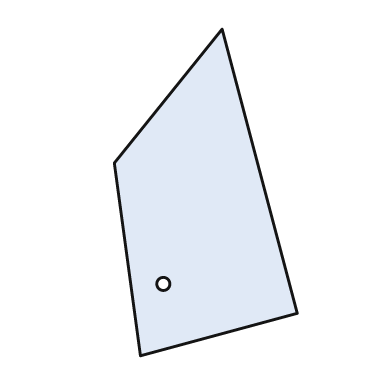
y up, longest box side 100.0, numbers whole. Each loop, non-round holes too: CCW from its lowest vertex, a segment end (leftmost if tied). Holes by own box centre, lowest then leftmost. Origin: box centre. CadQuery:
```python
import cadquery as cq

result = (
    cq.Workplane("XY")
    .moveTo(-20.0, -50.0)
    .lineTo(28.0, -37.0)
    .lineTo(5.0, 50.0)
    .lineTo(-28.0, 9.0)
    .close()
    .moveTo(-13.0, -28.0)
    .circle(2.0)
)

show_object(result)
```